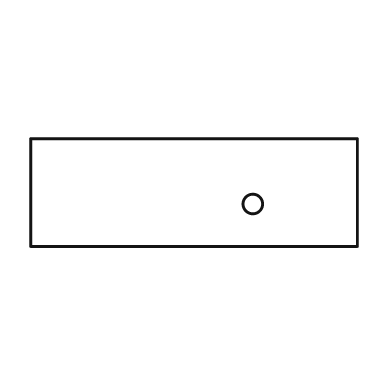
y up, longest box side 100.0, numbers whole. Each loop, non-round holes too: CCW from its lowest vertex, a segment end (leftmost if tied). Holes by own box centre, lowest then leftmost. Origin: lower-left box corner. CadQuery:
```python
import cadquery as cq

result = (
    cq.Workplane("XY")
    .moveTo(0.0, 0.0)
    .lineTo(100.0, 0.0)
    .lineTo(100.0, 33.0)
    .lineTo(0.0, 33.0)
    .close()
    .moveTo(68.0, 13.0)
    .circle(3.0)
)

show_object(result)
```